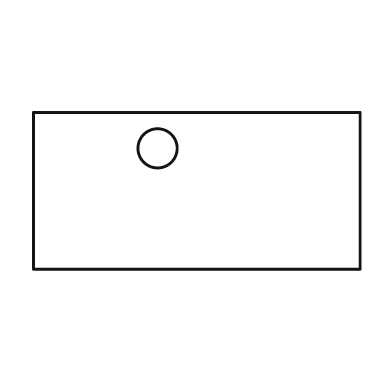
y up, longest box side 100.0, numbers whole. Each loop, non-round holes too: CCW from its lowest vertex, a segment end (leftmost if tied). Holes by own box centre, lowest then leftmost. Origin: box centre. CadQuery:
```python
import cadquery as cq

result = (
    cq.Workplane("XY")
    .moveTo(-50.0, -24.0)
    .lineTo(50.0, -24.0)
    .lineTo(50.0, 24.0)
    .lineTo(-50.0, 24.0)
    .close()
    .moveTo(-12.0, 13.0)
    .circle(6.0)
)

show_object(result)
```